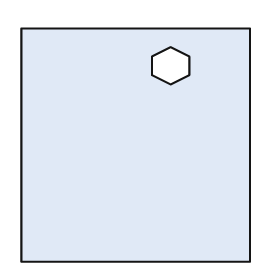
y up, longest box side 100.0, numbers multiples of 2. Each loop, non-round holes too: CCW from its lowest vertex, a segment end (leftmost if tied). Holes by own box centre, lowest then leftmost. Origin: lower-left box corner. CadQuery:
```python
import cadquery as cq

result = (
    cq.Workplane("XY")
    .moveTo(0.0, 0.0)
    .lineTo(98.0, 0.0)
    .lineTo(98.0, 100.0)
    .lineTo(0.0, 100.0)
    .close()
    .moveTo(64.0, 76.0)
    .lineTo(72.0, 80.0)
    .lineTo(72.0, 88.0)
    .lineTo(64.0, 92.0)
    .lineTo(56.0, 88.0)
    .lineTo(56.0, 80.0)
    .close()
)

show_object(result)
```